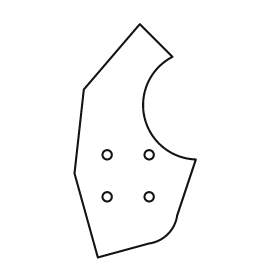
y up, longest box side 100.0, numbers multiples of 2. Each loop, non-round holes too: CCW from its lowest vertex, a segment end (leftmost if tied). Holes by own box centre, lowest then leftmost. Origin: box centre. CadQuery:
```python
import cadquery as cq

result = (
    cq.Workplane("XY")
    .moveTo(-16.0, -50.0)
    .lineTo(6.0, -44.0)
    .threePointArc((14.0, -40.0), (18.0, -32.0))
    .lineTo(26.0, -8.0)
    .threePointArc((4.0, 10.0), (16.0, 36.0))
    .lineTo(2.0, 50.0)
    .lineTo(-22.0, 22.0)
    .lineTo(-26.0, -14.0)
    .close()
    .moveTo(-12.0, -24.0)
    .circle(2.0)
    .moveTo(6.0, -24.0)
    .circle(2.0)
    .moveTo(-12.0, -6.0)
    .circle(2.0)
    .moveTo(6.0, -6.0)
    .circle(2.0)
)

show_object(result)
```